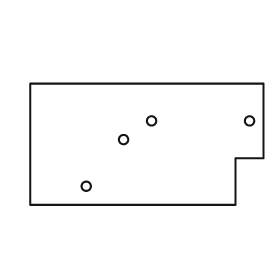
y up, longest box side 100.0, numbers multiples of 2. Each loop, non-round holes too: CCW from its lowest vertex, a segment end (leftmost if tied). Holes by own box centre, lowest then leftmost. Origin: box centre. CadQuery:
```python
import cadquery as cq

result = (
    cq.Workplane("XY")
    .moveTo(-50.0, -26.0)
    .lineTo(38.0, -26.0)
    .lineTo(38.0, -6.0)
    .lineTo(50.0, -6.0)
    .lineTo(50.0, 26.0)
    .lineTo(-50.0, 26.0)
    .close()
    .moveTo(-26.0, -18.0)
    .circle(2.0)
    .moveTo(-10.0, 2.0)
    .circle(2.0)
    .moveTo(2.0, 10.0)
    .circle(2.0)
    .moveTo(44.0, 10.0)
    .circle(2.0)
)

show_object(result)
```